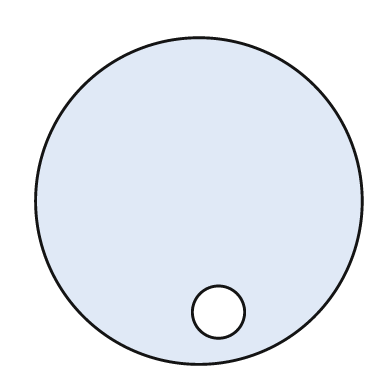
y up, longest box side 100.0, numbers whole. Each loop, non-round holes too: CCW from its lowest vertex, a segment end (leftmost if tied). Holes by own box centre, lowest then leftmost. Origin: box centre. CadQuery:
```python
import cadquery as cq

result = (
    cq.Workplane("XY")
    .moveTo(0.0, 0.0)
    .circle(50.0)
    .moveTo(6.0, -34.0)
    .circle(8.0)
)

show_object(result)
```